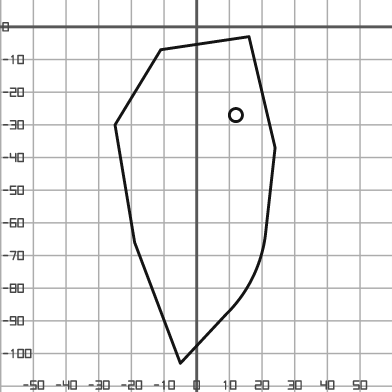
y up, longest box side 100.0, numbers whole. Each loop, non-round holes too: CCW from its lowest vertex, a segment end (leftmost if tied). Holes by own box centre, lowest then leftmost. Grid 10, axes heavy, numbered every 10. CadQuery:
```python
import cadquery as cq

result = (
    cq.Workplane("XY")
    .moveTo(-5.0, -103.0)
    .lineTo(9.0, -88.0)
    .threePointArc((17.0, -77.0), (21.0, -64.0))
    .lineTo(24.0, -37.0)
    .lineTo(16.0, -3.0)
    .lineTo(-11.0, -7.0)
    .lineTo(-25.0, -30.0)
    .lineTo(-19.0, -66.0)
    .close()
    .moveTo(12.0, -27.0)
    .circle(2.0)
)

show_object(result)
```